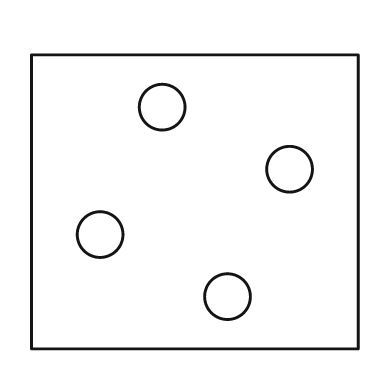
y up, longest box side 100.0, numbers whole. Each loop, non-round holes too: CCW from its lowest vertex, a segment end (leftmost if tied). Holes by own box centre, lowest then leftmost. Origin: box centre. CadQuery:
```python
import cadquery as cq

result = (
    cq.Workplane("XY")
    .moveTo(-50.0, -45.0)
    .lineTo(50.0, -45.0)
    .lineTo(50.0, 45.0)
    .lineTo(-50.0, 45.0)
    .close()
    .moveTo(10.0, -29.0)
    .circle(7.0)
    .moveTo(-29.0, -10.0)
    .circle(7.0)
    .moveTo(29.0, 10.0)
    .circle(7.0)
    .moveTo(-10.0, 29.0)
    .circle(7.0)
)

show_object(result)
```